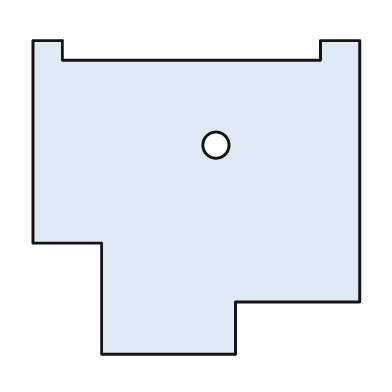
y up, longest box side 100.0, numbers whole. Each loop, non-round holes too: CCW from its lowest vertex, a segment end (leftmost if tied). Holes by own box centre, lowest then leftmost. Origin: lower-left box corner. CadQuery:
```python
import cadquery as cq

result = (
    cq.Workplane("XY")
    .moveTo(21.0, 0.0)
    .lineTo(62.0, 0.0)
    .lineTo(62.0, 16.0)
    .lineTo(100.0, 16.0)
    .lineTo(100.0, 96.0)
    .lineTo(88.0, 96.0)
    .lineTo(88.0, 90.0)
    .lineTo(9.0, 90.0)
    .lineTo(9.0, 96.0)
    .lineTo(0.0, 96.0)
    .lineTo(0.0, 34.0)
    .lineTo(21.0, 34.0)
    .close()
    .moveTo(56.0, 64.0)
    .circle(4.0)
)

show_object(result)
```